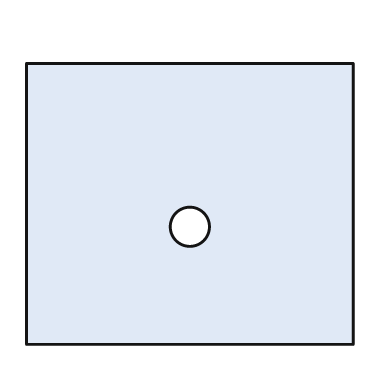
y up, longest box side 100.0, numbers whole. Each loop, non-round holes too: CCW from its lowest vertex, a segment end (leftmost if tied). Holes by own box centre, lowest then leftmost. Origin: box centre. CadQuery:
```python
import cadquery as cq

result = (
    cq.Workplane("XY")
    .moveTo(-50.0, -43.0)
    .lineTo(50.0, -43.0)
    .lineTo(50.0, 43.0)
    .lineTo(-50.0, 43.0)
    .close()
    .moveTo(0.0, -7.0)
    .circle(6.0)
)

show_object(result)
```